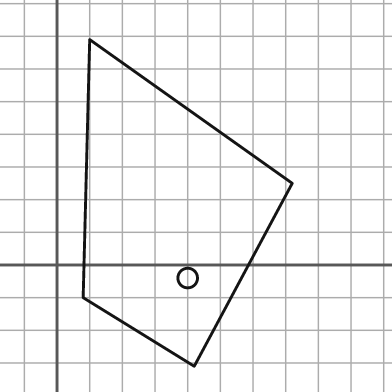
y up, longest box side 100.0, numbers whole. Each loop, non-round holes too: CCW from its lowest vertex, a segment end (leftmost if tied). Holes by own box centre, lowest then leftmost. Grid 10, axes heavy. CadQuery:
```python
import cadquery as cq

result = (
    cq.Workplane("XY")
    .moveTo(42.0, -31.0)
    .lineTo(72.0, 25.0)
    .lineTo(10.0, 69.0)
    .lineTo(8.0, -10.0)
    .close()
    .moveTo(40.0, -4.0)
    .circle(3.0)
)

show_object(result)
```